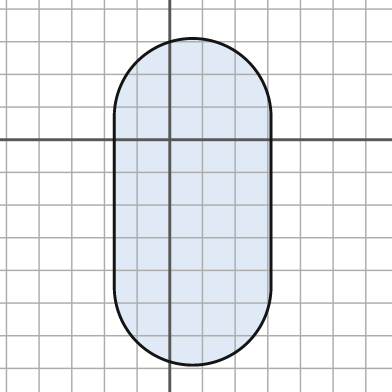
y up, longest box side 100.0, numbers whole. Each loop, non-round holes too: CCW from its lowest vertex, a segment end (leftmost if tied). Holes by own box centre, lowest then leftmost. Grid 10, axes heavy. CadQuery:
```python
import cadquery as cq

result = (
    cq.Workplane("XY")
    .moveTo(-17.0, -45.0)
    .threePointArc((7.0, -69.0), (31.0, -45.0))
    .lineTo(31.0, 7.0)
    .threePointArc((7.0, 31.0), (-17.0, 7.0))
    .close()
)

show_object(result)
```